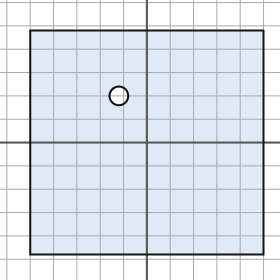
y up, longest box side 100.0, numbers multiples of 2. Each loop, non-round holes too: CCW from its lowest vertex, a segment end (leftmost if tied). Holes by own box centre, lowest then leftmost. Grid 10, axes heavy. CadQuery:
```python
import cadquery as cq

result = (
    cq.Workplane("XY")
    .moveTo(-50.0, -48.0)
    .lineTo(50.0, -48.0)
    .lineTo(50.0, 48.0)
    .lineTo(-50.0, 48.0)
    .close()
    .moveTo(-12.0, 20.0)
    .circle(4.0)
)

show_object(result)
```